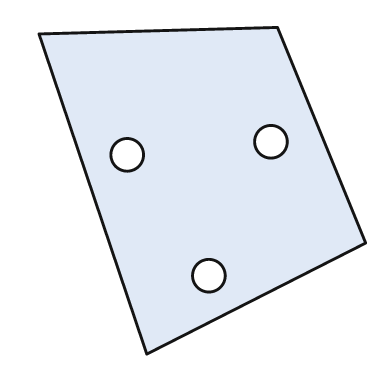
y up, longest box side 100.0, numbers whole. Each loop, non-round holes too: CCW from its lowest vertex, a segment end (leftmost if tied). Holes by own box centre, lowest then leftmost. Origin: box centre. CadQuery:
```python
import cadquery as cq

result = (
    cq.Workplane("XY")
    .moveTo(-17.0, -50.0)
    .lineTo(50.0, -16.0)
    .lineTo(23.0, 50.0)
    .lineTo(-50.0, 48.0)
    .close()
    .moveTo(2.0, -26.0)
    .circle(5.0)
    .moveTo(-23.0, 11.0)
    .circle(5.0)
    .moveTo(21.0, 15.0)
    .circle(5.0)
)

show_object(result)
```